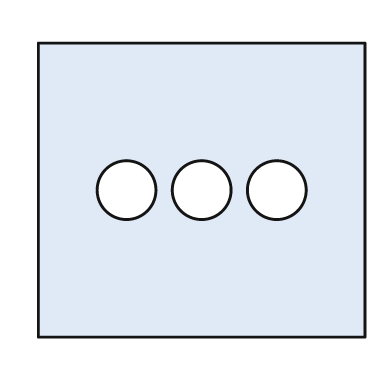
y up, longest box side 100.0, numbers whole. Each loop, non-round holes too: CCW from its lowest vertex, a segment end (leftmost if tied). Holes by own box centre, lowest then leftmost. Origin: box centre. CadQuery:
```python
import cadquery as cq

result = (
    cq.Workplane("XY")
    .moveTo(-50.0, -45.0)
    .lineTo(50.0, -45.0)
    .lineTo(50.0, 45.0)
    .lineTo(-50.0, 45.0)
    .close()
    .moveTo(-23.0, 0.0)
    .circle(9.0)
    .moveTo(0.0, 0.0)
    .circle(9.0)
    .moveTo(23.0, 0.0)
    .circle(9.0)
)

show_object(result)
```